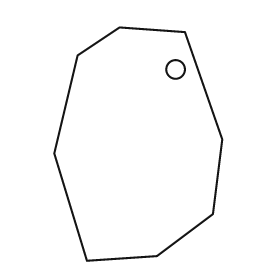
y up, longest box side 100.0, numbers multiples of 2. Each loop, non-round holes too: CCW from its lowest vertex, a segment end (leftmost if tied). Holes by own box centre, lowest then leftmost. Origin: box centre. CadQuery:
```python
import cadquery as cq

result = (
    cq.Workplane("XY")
    .moveTo(-22.0, -50.0)
    .lineTo(8.0, -48.0)
    .lineTo(32.0, -30.0)
    .lineTo(36.0, 2.0)
    .lineTo(20.0, 48.0)
    .lineTo(-8.0, 50.0)
    .lineTo(-26.0, 38.0)
    .lineTo(-36.0, -4.0)
    .close()
    .moveTo(16.0, 32.0)
    .circle(4.0)
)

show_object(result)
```